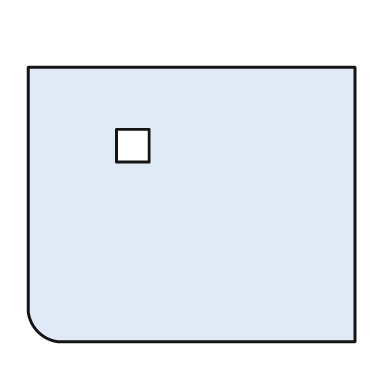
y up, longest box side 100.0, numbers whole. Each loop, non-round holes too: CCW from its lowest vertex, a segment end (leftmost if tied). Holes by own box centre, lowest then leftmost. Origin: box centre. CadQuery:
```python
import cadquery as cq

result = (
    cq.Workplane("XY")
    .moveTo(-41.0, -42.0)
    .lineTo(50.0, -42.0)
    .lineTo(50.0, 42.0)
    .lineTo(-50.0, 42.0)
    .lineTo(-50.0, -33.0)
    .threePointArc((-47.0, -39.0), (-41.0, -42.0))
    .close()
    .moveTo(-23.0, 13.0)
    .lineTo(-13.0, 13.0)
    .lineTo(-13.0, 23.0)
    .lineTo(-23.0, 23.0)
    .close()
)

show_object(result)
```